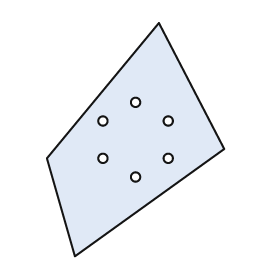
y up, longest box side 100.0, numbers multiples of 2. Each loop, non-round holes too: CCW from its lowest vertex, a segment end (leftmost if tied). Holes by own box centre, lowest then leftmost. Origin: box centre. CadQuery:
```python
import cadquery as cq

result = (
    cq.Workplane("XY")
    .moveTo(-26.0, -50.0)
    .lineTo(38.0, -4.0)
    .lineTo(10.0, 50.0)
    .lineTo(-38.0, -8.0)
    .close()
    .moveTo(0.0, -16.0)
    .circle(2.0)
    .moveTo(-14.0, -8.0)
    .circle(2.0)
    .moveTo(14.0, -8.0)
    .circle(2.0)
    .moveTo(-14.0, 8.0)
    .circle(2.0)
    .moveTo(14.0, 8.0)
    .circle(2.0)
    .moveTo(0.0, 16.0)
    .circle(2.0)
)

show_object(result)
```